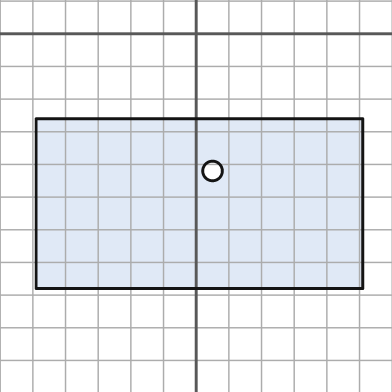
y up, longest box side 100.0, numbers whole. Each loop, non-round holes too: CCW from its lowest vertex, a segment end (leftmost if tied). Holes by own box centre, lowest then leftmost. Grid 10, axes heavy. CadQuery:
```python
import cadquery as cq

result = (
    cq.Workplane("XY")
    .moveTo(-49.0, -78.0)
    .lineTo(51.0, -78.0)
    .lineTo(51.0, -26.0)
    .lineTo(-49.0, -26.0)
    .close()
    .moveTo(5.0, -42.0)
    .circle(3.0)
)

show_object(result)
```